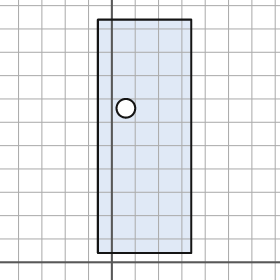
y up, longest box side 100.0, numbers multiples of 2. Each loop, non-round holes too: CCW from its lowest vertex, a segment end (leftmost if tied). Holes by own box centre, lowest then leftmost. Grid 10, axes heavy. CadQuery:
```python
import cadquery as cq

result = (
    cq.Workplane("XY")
    .moveTo(-6.0, 4.0)
    .lineTo(34.0, 4.0)
    .lineTo(34.0, 104.0)
    .lineTo(-6.0, 104.0)
    .close()
    .moveTo(6.0, 66.0)
    .circle(4.0)
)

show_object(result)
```